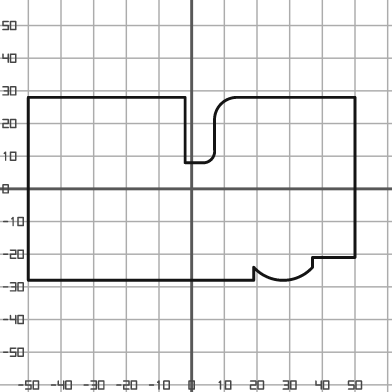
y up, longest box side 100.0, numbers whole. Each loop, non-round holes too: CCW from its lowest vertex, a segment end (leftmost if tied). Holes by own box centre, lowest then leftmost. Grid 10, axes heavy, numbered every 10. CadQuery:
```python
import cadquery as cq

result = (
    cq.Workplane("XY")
    .moveTo(-50.0, -28.0)
    .lineTo(19.0, -28.0)
    .lineTo(19.0, -24.0)
    .threePointArc((28.0, -28.0), (37.0, -24.0))
    .lineTo(37.0, -21.0)
    .lineTo(50.0, -21.0)
    .lineTo(50.0, 28.0)
    .lineTo(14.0, 28.0)
    .threePointArc((9.0, 26.0), (7.0, 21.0))
    .lineTo(7.0, 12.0)
    .threePointArc((6.0, 9.0), (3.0, 8.0))
    .lineTo(-2.0, 8.0)
    .lineTo(-2.0, 28.0)
    .lineTo(-50.0, 28.0)
    .close()
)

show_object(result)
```